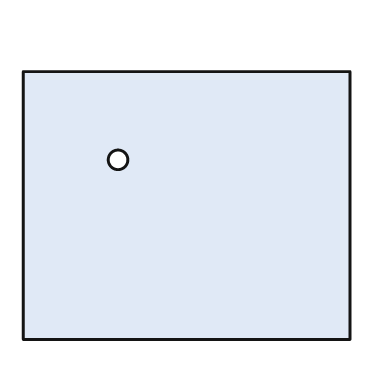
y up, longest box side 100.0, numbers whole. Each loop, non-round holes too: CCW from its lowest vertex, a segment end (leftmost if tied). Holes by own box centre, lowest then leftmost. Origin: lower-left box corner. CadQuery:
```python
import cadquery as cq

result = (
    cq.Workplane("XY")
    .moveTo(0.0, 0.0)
    .lineTo(100.0, 0.0)
    .lineTo(100.0, 82.0)
    .lineTo(0.0, 82.0)
    .close()
    .moveTo(29.0, 55.0)
    .circle(3.0)
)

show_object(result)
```